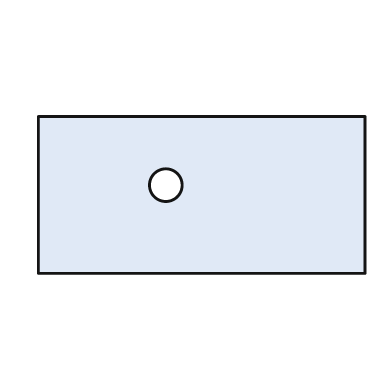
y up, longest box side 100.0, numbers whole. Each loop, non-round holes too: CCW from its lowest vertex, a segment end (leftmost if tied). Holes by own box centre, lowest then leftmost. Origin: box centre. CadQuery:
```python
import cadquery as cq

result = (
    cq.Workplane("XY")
    .moveTo(-50.0, -24.0)
    .lineTo(50.0, -24.0)
    .lineTo(50.0, 24.0)
    .lineTo(-50.0, 24.0)
    .close()
    .moveTo(-11.0, 3.0)
    .circle(5.0)
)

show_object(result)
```